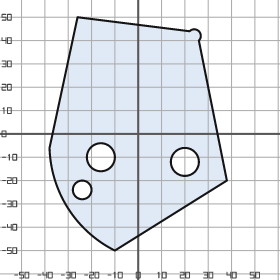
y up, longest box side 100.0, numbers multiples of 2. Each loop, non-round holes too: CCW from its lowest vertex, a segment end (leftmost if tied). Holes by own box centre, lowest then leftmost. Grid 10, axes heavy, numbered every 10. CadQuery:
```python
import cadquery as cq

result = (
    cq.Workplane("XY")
    .moveTo(-10.0, -50.0)
    .lineTo(38.0, -20.0)
    .lineTo(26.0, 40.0)
    .threePointArc((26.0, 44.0), (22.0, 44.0))
    .lineTo(-26.0, 50.0)
    .lineTo(-38.0, -6.0)
    .threePointArc((-30.0, -32.0), (-10.0, -50.0))
    .close()
    .moveTo(-24.0, -24.0)
    .circle(4.0)
    .moveTo(20.0, -12.0)
    .circle(6.0)
    .moveTo(-16.0, -10.0)
    .circle(6.0)
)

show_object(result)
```